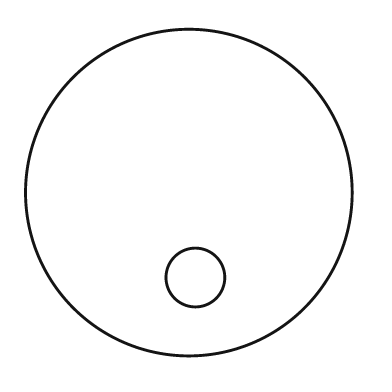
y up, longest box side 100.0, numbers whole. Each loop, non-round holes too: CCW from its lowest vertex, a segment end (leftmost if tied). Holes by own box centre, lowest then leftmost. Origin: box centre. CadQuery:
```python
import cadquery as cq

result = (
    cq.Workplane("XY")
    .moveTo(0.0, 0.0)
    .circle(50.0)
    .moveTo(2.0, -26.0)
    .circle(9.0)
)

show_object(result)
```